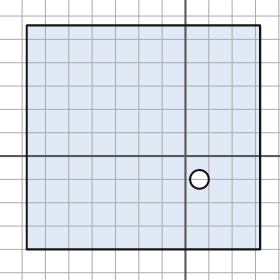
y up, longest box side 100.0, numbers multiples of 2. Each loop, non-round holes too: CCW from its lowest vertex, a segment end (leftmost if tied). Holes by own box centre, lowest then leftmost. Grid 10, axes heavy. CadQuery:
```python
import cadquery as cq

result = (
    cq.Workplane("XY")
    .moveTo(-68.0, -40.0)
    .lineTo(32.0, -40.0)
    .lineTo(32.0, 56.0)
    .lineTo(-68.0, 56.0)
    .close()
    .moveTo(6.0, -10.0)
    .circle(4.0)
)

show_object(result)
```